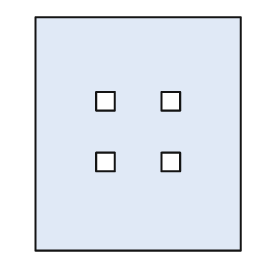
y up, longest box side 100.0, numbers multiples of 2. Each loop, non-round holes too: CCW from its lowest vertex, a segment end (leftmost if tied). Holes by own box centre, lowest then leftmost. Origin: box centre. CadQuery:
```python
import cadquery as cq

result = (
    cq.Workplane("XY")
    .moveTo(-44.0, -50.0)
    .lineTo(44.0, -50.0)
    .lineTo(44.0, 50.0)
    .lineTo(-44.0, 50.0)
    .close()
    .moveTo(-18.0, -16.0)
    .lineTo(-10.0, -16.0)
    .lineTo(-10.0, -8.0)
    .lineTo(-18.0, -8.0)
    .close()
    .moveTo(10.0, -16.0)
    .lineTo(18.0, -16.0)
    .lineTo(18.0, -8.0)
    .lineTo(10.0, -8.0)
    .close()
    .moveTo(-18.0, 10.0)
    .lineTo(-10.0, 10.0)
    .lineTo(-10.0, 18.0)
    .lineTo(-18.0, 18.0)
    .close()
    .moveTo(10.0, 10.0)
    .lineTo(18.0, 10.0)
    .lineTo(18.0, 18.0)
    .lineTo(10.0, 18.0)
    .close()
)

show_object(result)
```